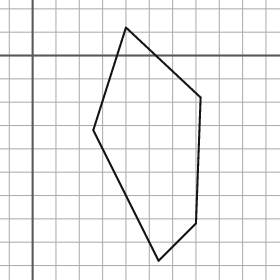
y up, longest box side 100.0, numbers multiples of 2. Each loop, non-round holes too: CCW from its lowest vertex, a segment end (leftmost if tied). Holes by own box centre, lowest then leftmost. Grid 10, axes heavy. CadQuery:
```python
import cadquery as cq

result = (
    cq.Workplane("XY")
    .moveTo(54.0, -88.0)
    .lineTo(70.0, -72.0)
    .lineTo(72.0, -18.0)
    .lineTo(40.0, 12.0)
    .lineTo(26.0, -32.0)
    .close()
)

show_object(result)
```